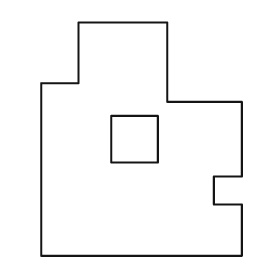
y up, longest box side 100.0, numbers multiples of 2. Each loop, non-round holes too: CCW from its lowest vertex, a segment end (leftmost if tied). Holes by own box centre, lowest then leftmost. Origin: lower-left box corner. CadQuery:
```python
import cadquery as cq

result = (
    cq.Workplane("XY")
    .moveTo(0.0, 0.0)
    .lineTo(86.0, 0.0)
    .lineTo(86.0, 22.0)
    .lineTo(74.0, 22.0)
    .lineTo(74.0, 34.0)
    .lineTo(86.0, 34.0)
    .lineTo(86.0, 66.0)
    .lineTo(54.0, 66.0)
    .lineTo(54.0, 100.0)
    .lineTo(16.0, 100.0)
    .lineTo(16.0, 74.0)
    .lineTo(0.0, 74.0)
    .close()
    .moveTo(30.0, 40.0)
    .lineTo(50.0, 40.0)
    .lineTo(50.0, 60.0)
    .lineTo(30.0, 60.0)
    .close()
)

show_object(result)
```